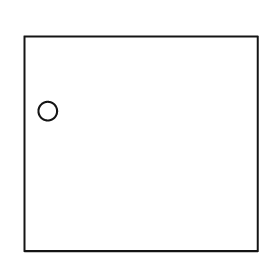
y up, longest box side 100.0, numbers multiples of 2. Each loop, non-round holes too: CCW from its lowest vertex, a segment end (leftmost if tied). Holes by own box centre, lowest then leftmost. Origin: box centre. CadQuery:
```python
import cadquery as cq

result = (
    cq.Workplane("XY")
    .moveTo(-50.0, -46.0)
    .lineTo(50.0, -46.0)
    .lineTo(50.0, 46.0)
    .lineTo(-50.0, 46.0)
    .close()
    .moveTo(-40.0, 14.0)
    .circle(4.0)
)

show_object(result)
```